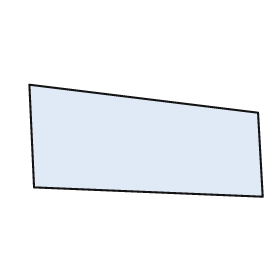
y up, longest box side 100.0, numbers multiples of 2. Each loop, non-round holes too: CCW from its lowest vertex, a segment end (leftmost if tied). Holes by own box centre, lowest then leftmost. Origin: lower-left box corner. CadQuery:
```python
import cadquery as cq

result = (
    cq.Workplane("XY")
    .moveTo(100.0, 0.0)
    .lineTo(98.0, 36.0)
    .lineTo(0.0, 48.0)
    .lineTo(2.0, 4.0)
    .close()
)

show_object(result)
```